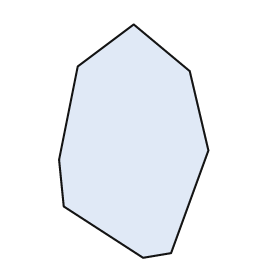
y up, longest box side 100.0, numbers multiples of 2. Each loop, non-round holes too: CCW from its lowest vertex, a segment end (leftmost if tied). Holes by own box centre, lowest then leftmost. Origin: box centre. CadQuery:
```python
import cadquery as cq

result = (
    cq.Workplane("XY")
    .moveTo(4.0, -50.0)
    .lineTo(16.0, -48.0)
    .lineTo(32.0, -4.0)
    .lineTo(24.0, 30.0)
    .lineTo(0.0, 50.0)
    .lineTo(-24.0, 32.0)
    .lineTo(-32.0, -8.0)
    .lineTo(-30.0, -28.0)
    .close()
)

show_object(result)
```